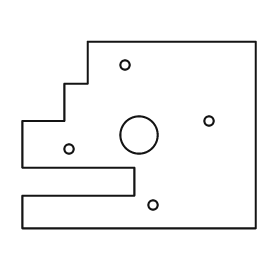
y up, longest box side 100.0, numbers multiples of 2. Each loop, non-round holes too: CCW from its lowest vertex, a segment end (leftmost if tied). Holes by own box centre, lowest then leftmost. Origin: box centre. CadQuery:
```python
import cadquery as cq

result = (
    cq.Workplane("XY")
    .moveTo(-50.0, -40.0)
    .lineTo(50.0, -40.0)
    .lineTo(50.0, 40.0)
    .lineTo(-22.0, 40.0)
    .lineTo(-22.0, 22.0)
    .lineTo(-32.0, 22.0)
    .lineTo(-32.0, 6.0)
    .lineTo(-50.0, 6.0)
    .lineTo(-50.0, -14.0)
    .lineTo(-2.0, -14.0)
    .lineTo(-2.0, -26.0)
    .lineTo(-50.0, -26.0)
    .close()
    .moveTo(6.0, -30.0)
    .circle(2.0)
    .moveTo(-30.0, -6.0)
    .circle(2.0)
    .moveTo(0.0, 0.0)
    .circle(8.0)
    .moveTo(30.0, 6.0)
    .circle(2.0)
    .moveTo(-6.0, 30.0)
    .circle(2.0)
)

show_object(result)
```